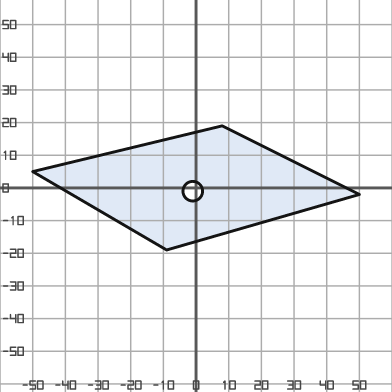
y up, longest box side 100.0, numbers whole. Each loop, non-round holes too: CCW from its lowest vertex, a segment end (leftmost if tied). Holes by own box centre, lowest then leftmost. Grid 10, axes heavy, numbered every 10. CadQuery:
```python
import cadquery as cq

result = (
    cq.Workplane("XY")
    .moveTo(-9.0, -19.0)
    .lineTo(50.0, -2.0)
    .lineTo(8.0, 19.0)
    .lineTo(-50.0, 5.0)
    .close()
    .moveTo(-1.0, -1.0)
    .circle(3.0)
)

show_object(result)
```